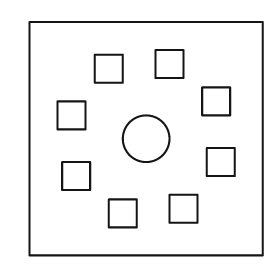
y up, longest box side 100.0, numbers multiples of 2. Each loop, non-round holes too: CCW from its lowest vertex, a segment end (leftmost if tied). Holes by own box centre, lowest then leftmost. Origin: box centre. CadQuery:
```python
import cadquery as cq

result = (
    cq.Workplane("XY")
    .moveTo(-50.0, -50.0)
    .lineTo(50.0, -50.0)
    .lineTo(50.0, 50.0)
    .lineTo(-50.0, 50.0)
    .close()
    .moveTo(-16.0, -38.0)
    .lineTo(-4.0, -38.0)
    .lineTo(-4.0, -26.0)
    .lineTo(-16.0, -26.0)
    .close()
    .moveTo(10.0, -36.0)
    .lineTo(22.0, -36.0)
    .lineTo(22.0, -24.0)
    .lineTo(10.0, -24.0)
    .close()
    .moveTo(-36.0, -22.0)
    .lineTo(-24.0, -22.0)
    .lineTo(-24.0, -10.0)
    .lineTo(-36.0, -10.0)
    .close()
    .moveTo(26.0, -16.0)
    .lineTo(38.0, -16.0)
    .lineTo(38.0, -4.0)
    .lineTo(26.0, -4.0)
    .close()
    .moveTo(0.0, 0.0)
    .circle(10.0)
    .moveTo(-38.0, 4.0)
    .lineTo(-26.0, 4.0)
    .lineTo(-26.0, 16.0)
    .lineTo(-38.0, 16.0)
    .close()
    .moveTo(24.0, 10.0)
    .lineTo(36.0, 10.0)
    .lineTo(36.0, 22.0)
    .lineTo(24.0, 22.0)
    .close()
    .moveTo(-22.0, 24.0)
    .lineTo(-10.0, 24.0)
    .lineTo(-10.0, 36.0)
    .lineTo(-22.0, 36.0)
    .close()
    .moveTo(4.0, 26.0)
    .lineTo(16.0, 26.0)
    .lineTo(16.0, 38.0)
    .lineTo(4.0, 38.0)
    .close()
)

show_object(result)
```